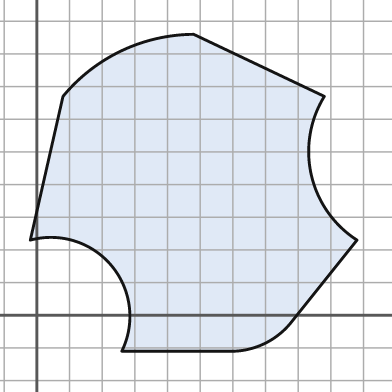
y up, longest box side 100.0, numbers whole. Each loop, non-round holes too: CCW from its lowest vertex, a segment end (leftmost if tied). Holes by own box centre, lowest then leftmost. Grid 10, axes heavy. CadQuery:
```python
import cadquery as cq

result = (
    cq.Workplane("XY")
    .moveTo(26.0, -11.0)
    .lineTo(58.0, -11.0)
    .threePointArc((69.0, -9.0), (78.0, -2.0))
    .lineTo(98.0, 23.0)
    .threePointArc((84.0, 43.0), (88.0, 67.0))
    .lineTo(48.0, 86.0)
    .threePointArc((26.0, 81.0), (8.0, 67.0))
    .lineTo(-2.0, 23.0)
    .threePointArc((23.0, 15.0), (26.0, -11.0))
    .close()
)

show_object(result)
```